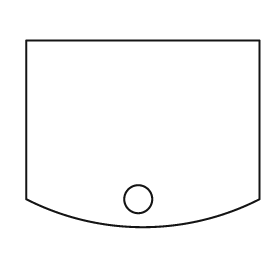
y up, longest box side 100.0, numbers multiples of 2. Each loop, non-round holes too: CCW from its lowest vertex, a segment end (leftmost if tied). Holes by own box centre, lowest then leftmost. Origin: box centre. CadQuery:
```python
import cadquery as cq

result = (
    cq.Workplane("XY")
    .moveTo(-50.0, -28.0)
    .threePointArc((0.0, -40.0), (50.0, -28.0))
    .lineTo(50.0, 40.0)
    .lineTo(-50.0, 40.0)
    .close()
    .moveTo(-2.0, -28.0)
    .circle(6.0)
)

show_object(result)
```